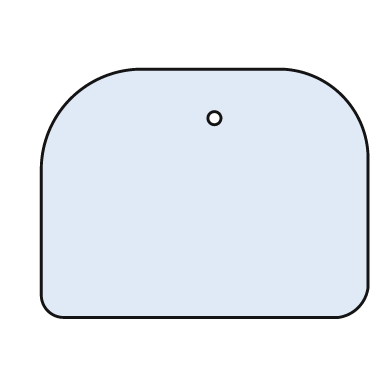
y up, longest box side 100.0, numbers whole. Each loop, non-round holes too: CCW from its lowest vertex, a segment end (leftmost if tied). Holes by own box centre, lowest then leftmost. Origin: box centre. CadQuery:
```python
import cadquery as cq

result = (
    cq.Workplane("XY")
    .moveTo(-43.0, -38.0)
    .lineTo(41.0, -38.0)
    .threePointArc((47.0, -35.0), (50.0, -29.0))
    .lineTo(50.0, 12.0)
    .threePointArc((42.0, 30.0), (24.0, 38.0))
    .lineTo(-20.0, 38.0)
    .threePointArc((-41.0, 29.0), (-50.0, 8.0))
    .lineTo(-50.0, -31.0)
    .threePointArc((-48.0, -36.0), (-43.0, -38.0))
    .close()
    .moveTo(3.0, 23.0)
    .circle(2.0)
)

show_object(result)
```